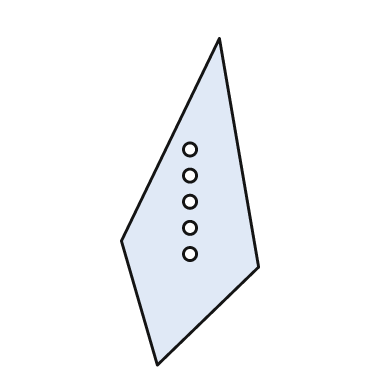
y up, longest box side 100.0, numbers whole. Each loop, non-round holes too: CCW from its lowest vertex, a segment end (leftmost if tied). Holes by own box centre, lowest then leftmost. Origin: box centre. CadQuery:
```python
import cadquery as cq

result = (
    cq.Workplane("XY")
    .moveTo(-10.0, -50.0)
    .lineTo(21.0, -20.0)
    .lineTo(9.0, 50.0)
    .lineTo(-21.0, -12.0)
    .close()
    .moveTo(0.0, -16.0)
    .circle(2.0)
    .moveTo(0.0, -8.0)
    .circle(2.0)
    .moveTo(0.0, 0.0)
    .circle(2.0)
    .moveTo(0.0, 8.0)
    .circle(2.0)
    .moveTo(0.0, 16.0)
    .circle(2.0)
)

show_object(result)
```